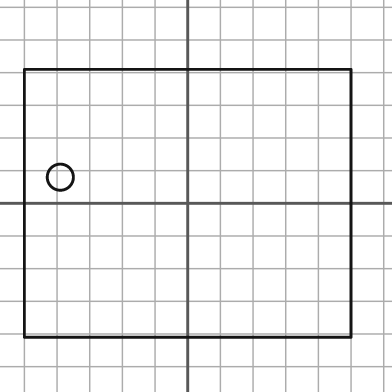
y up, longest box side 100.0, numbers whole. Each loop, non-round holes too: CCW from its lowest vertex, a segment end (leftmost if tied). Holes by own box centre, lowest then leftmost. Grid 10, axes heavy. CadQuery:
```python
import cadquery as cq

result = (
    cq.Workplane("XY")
    .moveTo(-50.0, -41.0)
    .lineTo(50.0, -41.0)
    .lineTo(50.0, 41.0)
    .lineTo(-50.0, 41.0)
    .close()
    .moveTo(-39.0, 8.0)
    .circle(4.0)
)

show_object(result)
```